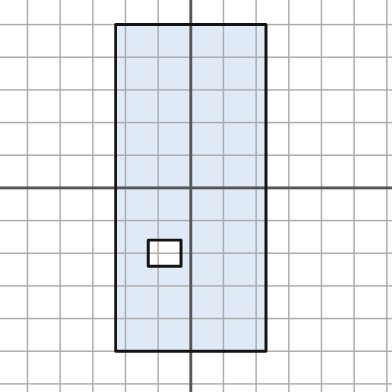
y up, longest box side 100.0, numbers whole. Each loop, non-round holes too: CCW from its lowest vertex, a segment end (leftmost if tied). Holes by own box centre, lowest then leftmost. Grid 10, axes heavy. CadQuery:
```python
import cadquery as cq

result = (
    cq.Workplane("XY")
    .moveTo(-23.0, -50.0)
    .lineTo(23.0, -50.0)
    .lineTo(23.0, 50.0)
    .lineTo(-23.0, 50.0)
    .close()
    .moveTo(-13.0, -24.0)
    .lineTo(-3.0, -24.0)
    .lineTo(-3.0, -16.0)
    .lineTo(-13.0, -16.0)
    .close()
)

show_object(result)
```